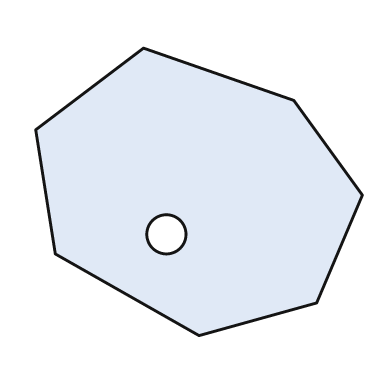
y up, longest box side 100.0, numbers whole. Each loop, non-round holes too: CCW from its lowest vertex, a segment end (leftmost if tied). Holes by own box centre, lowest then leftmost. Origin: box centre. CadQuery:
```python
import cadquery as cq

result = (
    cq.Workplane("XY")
    .moveTo(0.0, -44.0)
    .lineTo(36.0, -34.0)
    .lineTo(50.0, -1.0)
    .lineTo(29.0, 28.0)
    .lineTo(-17.0, 44.0)
    .lineTo(-50.0, 19.0)
    .lineTo(-44.0, -19.0)
    .close()
    .moveTo(-10.0, -13.0)
    .circle(6.0)
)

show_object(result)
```